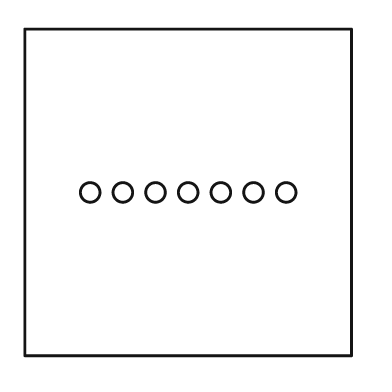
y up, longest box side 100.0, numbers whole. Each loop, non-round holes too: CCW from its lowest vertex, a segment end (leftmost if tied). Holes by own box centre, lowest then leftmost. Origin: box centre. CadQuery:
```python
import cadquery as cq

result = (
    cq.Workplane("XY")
    .moveTo(-50.0, -50.0)
    .lineTo(50.0, -50.0)
    .lineTo(50.0, 50.0)
    .lineTo(-50.0, 50.0)
    .close()
    .moveTo(-30.0, 0.0)
    .circle(3.0)
    .moveTo(-20.0, 0.0)
    .circle(3.0)
    .moveTo(-10.0, 0.0)
    .circle(3.0)
    .moveTo(0.0, 0.0)
    .circle(3.0)
    .moveTo(10.0, 0.0)
    .circle(3.0)
    .moveTo(20.0, 0.0)
    .circle(3.0)
    .moveTo(30.0, 0.0)
    .circle(3.0)
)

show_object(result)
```